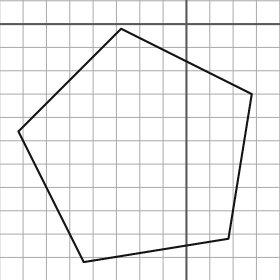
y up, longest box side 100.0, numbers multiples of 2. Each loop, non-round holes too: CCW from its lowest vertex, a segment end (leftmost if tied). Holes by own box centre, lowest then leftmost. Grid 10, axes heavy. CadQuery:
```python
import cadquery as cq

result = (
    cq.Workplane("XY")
    .moveTo(-44.0, -102.0)
    .lineTo(18.0, -92.0)
    .lineTo(28.0, -30.0)
    .lineTo(-28.0, -2.0)
    .lineTo(-72.0, -46.0)
    .close()
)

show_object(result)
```